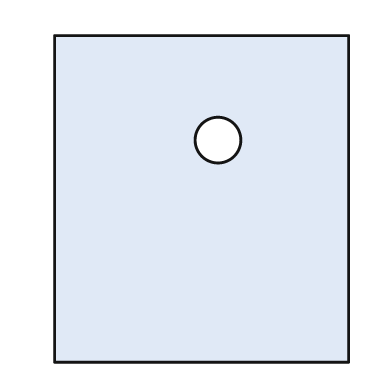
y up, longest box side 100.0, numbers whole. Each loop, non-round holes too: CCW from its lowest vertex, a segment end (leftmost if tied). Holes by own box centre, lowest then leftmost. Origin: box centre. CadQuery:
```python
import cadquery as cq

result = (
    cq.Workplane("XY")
    .moveTo(-45.0, -50.0)
    .lineTo(45.0, -50.0)
    .lineTo(45.0, 50.0)
    .lineTo(-45.0, 50.0)
    .close()
    .moveTo(5.0, 18.0)
    .circle(7.0)
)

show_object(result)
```